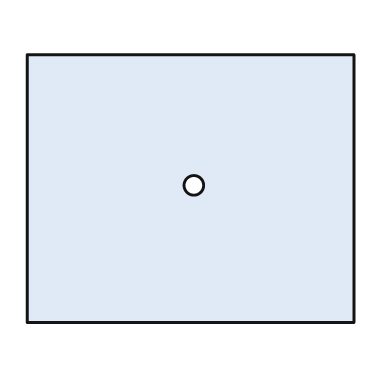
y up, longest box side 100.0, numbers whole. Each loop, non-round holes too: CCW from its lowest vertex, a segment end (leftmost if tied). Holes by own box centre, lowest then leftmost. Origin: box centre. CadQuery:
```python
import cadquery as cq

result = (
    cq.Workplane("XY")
    .moveTo(-50.0, -41.0)
    .lineTo(50.0, -41.0)
    .lineTo(50.0, 41.0)
    .lineTo(-50.0, 41.0)
    .close()
    .moveTo(1.0, 1.0)
    .circle(3.0)
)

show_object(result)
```